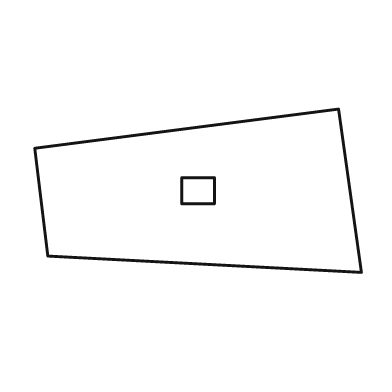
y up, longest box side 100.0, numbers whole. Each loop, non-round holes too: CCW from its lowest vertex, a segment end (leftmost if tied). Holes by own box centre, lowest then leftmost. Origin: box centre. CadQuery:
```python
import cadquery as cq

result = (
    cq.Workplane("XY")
    .moveTo(50.0, -25.0)
    .lineTo(43.0, 25.0)
    .lineTo(-50.0, 13.0)
    .lineTo(-46.0, -20.0)
    .close()
    .moveTo(-5.0, -4.0)
    .lineTo(5.0, -4.0)
    .lineTo(5.0, 4.0)
    .lineTo(-5.0, 4.0)
    .close()
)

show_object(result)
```